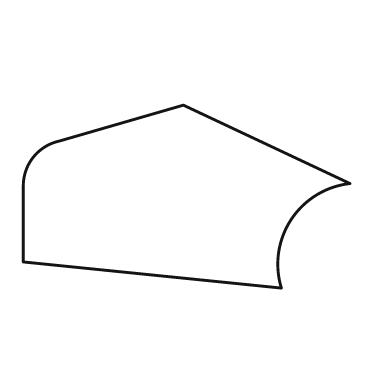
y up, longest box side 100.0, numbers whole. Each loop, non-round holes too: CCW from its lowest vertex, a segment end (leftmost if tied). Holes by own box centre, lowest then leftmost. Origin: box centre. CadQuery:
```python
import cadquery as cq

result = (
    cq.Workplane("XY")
    .moveTo(29.0, -28.0)
    .threePointArc((32.0, -7.0), (50.0, 4.0))
    .lineTo(-1.0, 28.0)
    .lineTo(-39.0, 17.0)
    .threePointArc((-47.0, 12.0), (-50.0, 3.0))
    .lineTo(-50.0, -20.0)
    .close()
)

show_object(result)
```